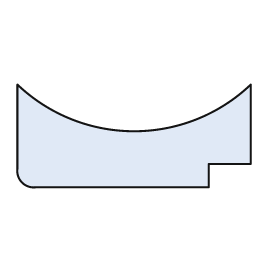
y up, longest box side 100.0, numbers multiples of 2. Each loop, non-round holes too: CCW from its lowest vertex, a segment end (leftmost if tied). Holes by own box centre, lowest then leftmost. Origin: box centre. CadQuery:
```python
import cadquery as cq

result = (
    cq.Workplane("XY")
    .moveTo(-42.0, -22.0)
    .lineTo(32.0, -22.0)
    .lineTo(32.0, -12.0)
    .lineTo(50.0, -12.0)
    .lineTo(50.0, 22.0)
    .threePointArc((0.0, 2.0), (-50.0, 22.0))
    .lineTo(-50.0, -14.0)
    .threePointArc((-48.0, -20.0), (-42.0, -22.0))
    .close()
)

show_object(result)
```